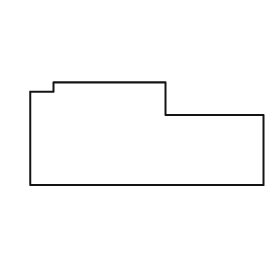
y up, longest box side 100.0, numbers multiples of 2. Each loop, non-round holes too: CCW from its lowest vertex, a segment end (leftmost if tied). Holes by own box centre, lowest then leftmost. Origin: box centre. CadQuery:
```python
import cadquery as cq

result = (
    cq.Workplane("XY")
    .moveTo(-50.0, -22.0)
    .lineTo(50.0, -22.0)
    .lineTo(50.0, 8.0)
    .lineTo(8.0, 8.0)
    .lineTo(8.0, 22.0)
    .lineTo(-40.0, 22.0)
    .lineTo(-40.0, 18.0)
    .lineTo(-50.0, 18.0)
    .close()
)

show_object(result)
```